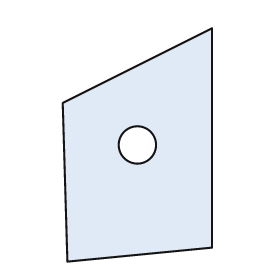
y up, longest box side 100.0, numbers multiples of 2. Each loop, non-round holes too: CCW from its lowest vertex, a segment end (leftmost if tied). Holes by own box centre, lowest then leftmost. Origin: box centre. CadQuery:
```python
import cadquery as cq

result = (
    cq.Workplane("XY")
    .moveTo(-30.0, -50.0)
    .lineTo(32.0, -44.0)
    .lineTo(32.0, 50.0)
    .lineTo(-32.0, 18.0)
    .close()
    .moveTo(0.0, 0.0)
    .circle(8.0)
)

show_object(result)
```